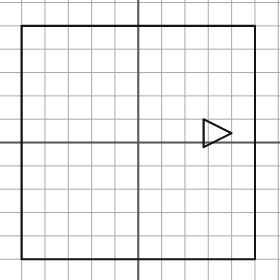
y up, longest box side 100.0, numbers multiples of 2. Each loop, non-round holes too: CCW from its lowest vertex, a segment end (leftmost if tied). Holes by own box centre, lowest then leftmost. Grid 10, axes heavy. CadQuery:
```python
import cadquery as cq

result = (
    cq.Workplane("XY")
    .moveTo(-50.0, -50.0)
    .lineTo(50.0, -50.0)
    .lineTo(50.0, 50.0)
    .lineTo(-50.0, 50.0)
    .close()
    .moveTo(28.0, -2.0)
    .lineTo(40.0, 4.0)
    .lineTo(28.0, 10.0)
    .close()
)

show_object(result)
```